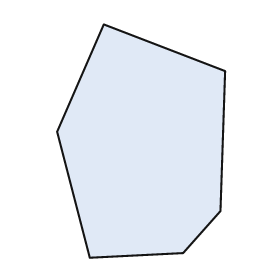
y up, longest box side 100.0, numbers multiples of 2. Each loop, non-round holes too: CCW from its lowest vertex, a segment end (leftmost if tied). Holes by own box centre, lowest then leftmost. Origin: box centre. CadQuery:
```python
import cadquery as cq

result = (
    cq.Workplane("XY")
    .moveTo(-22.0, -50.0)
    .lineTo(18.0, -48.0)
    .lineTo(34.0, -30.0)
    .lineTo(36.0, 30.0)
    .lineTo(-16.0, 50.0)
    .lineTo(-36.0, 4.0)
    .close()
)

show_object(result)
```